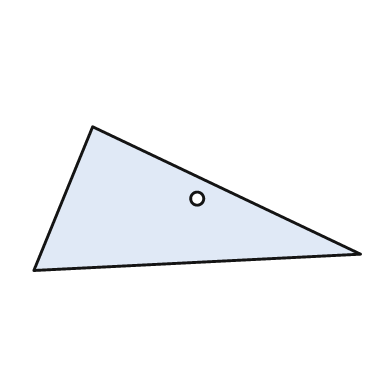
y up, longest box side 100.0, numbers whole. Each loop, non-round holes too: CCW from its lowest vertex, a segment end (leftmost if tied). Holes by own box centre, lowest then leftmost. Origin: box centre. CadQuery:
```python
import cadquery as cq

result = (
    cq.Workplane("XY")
    .moveTo(-50.0, -22.0)
    .lineTo(50.0, -17.0)
    .lineTo(-32.0, 22.0)
    .close()
    .moveTo(0.0, 0.0)
    .circle(2.0)
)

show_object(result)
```